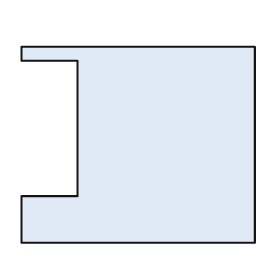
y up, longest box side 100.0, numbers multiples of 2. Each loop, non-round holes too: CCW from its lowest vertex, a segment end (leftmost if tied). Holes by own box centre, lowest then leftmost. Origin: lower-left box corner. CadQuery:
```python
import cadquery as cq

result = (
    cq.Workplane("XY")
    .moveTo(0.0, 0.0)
    .lineTo(100.0, 0.0)
    .lineTo(100.0, 84.0)
    .lineTo(0.0, 84.0)
    .lineTo(0.0, 78.0)
    .lineTo(24.0, 78.0)
    .lineTo(24.0, 20.0)
    .lineTo(0.0, 20.0)
    .close()
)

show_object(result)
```